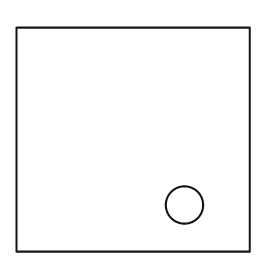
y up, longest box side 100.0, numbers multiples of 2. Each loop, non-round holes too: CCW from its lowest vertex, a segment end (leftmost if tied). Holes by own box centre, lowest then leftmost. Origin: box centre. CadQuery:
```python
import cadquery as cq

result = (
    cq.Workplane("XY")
    .moveTo(-50.0, -48.0)
    .lineTo(50.0, -48.0)
    .lineTo(50.0, 48.0)
    .lineTo(-50.0, 48.0)
    .close()
    .moveTo(22.0, -28.0)
    .circle(8.0)
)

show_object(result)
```